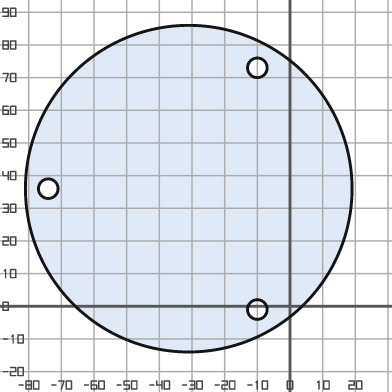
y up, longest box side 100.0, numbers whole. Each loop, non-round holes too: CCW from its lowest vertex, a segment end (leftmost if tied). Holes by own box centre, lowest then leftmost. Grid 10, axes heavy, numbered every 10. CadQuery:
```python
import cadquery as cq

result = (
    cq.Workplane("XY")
    .moveTo(-31.0, 36.0)
    .circle(50.0)
    .moveTo(-10.0, -1.0)
    .circle(3.0)
    .moveTo(-74.0, 36.0)
    .circle(3.0)
    .moveTo(-10.0, 73.0)
    .circle(3.0)
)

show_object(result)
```